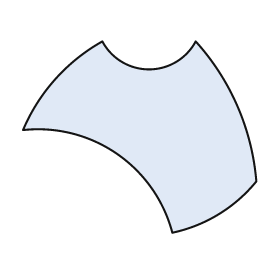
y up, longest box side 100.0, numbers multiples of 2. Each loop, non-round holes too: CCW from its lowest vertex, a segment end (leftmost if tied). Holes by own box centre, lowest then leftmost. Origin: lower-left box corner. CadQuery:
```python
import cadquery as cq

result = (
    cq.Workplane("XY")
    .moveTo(64.0, 0.0)
    .threePointArc((84.0, 8.0), (100.0, 22.0))
    .threePointArc((92.0, 54.0), (74.0, 82.0))
    .threePointArc((54.0, 70.0), (34.0, 82.0))
    .threePointArc((14.0, 66.0), (0.0, 44.0))
    .threePointArc((40.0, 34.0), (64.0, 0.0))
    .close()
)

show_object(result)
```